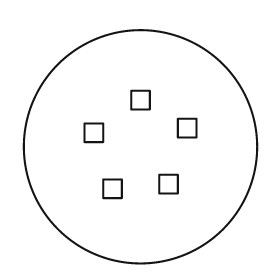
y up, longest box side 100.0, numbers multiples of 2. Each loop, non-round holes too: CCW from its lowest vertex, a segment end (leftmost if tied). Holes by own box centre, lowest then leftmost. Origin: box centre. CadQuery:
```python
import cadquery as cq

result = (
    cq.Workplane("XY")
    .moveTo(0.0, 0.0)
    .circle(50.0)
    .moveTo(-16.0, -22.0)
    .lineTo(-8.0, -22.0)
    .lineTo(-8.0, -14.0)
    .lineTo(-16.0, -14.0)
    .close()
    .moveTo(8.0, -20.0)
    .lineTo(16.0, -20.0)
    .lineTo(16.0, -12.0)
    .lineTo(8.0, -12.0)
    .close()
    .moveTo(-24.0, 2.0)
    .lineTo(-16.0, 2.0)
    .lineTo(-16.0, 10.0)
    .lineTo(-24.0, 10.0)
    .close()
    .moveTo(16.0, 4.0)
    .lineTo(24.0, 4.0)
    .lineTo(24.0, 12.0)
    .lineTo(16.0, 12.0)
    .close()
    .moveTo(-4.0, 16.0)
    .lineTo(4.0, 16.0)
    .lineTo(4.0, 24.0)
    .lineTo(-4.0, 24.0)
    .close()
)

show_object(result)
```